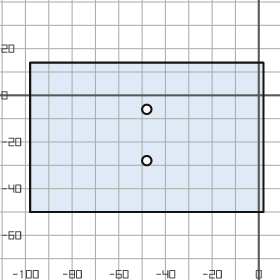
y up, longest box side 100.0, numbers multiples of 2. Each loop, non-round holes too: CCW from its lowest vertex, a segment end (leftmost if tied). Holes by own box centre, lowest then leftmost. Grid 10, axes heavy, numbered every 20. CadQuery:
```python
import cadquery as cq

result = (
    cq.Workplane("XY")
    .moveTo(-98.0, -50.0)
    .lineTo(2.0, -50.0)
    .lineTo(2.0, 14.0)
    .lineTo(-98.0, 14.0)
    .close()
    .moveTo(-48.0, -28.0)
    .circle(2.0)
    .moveTo(-48.0, -6.0)
    .circle(2.0)
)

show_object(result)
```